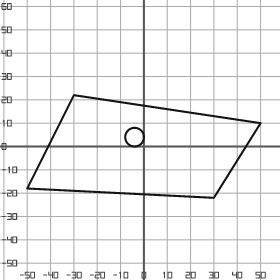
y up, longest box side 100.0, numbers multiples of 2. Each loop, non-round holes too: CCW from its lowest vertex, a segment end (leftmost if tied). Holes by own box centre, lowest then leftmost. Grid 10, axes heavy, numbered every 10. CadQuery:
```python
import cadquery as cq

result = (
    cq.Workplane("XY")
    .moveTo(30.0, -22.0)
    .lineTo(50.0, 10.0)
    .lineTo(-30.0, 22.0)
    .lineTo(-50.0, -18.0)
    .close()
    .moveTo(-4.0, 4.0)
    .circle(4.0)
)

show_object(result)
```